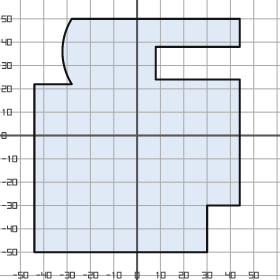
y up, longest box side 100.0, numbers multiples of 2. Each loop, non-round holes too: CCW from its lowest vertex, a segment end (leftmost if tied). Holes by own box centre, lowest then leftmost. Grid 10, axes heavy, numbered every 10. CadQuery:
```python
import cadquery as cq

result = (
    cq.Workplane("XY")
    .moveTo(-44.0, -50.0)
    .lineTo(30.0, -50.0)
    .lineTo(30.0, -30.0)
    .lineTo(44.0, -30.0)
    .lineTo(44.0, 24.0)
    .lineTo(8.0, 24.0)
    .lineTo(8.0, 38.0)
    .lineTo(44.0, 38.0)
    .lineTo(44.0, 50.0)
    .lineTo(-28.0, 50.0)
    .threePointArc((-32.0, 36.0), (-28.0, 22.0))
    .lineTo(-44.0, 22.0)
    .close()
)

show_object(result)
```